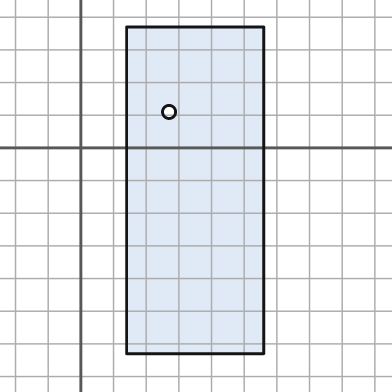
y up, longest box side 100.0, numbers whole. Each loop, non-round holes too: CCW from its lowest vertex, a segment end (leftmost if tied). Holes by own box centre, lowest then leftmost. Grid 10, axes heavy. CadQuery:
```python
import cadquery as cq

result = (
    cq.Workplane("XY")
    .moveTo(14.0, -63.0)
    .lineTo(56.0, -63.0)
    .lineTo(56.0, 37.0)
    .lineTo(14.0, 37.0)
    .close()
    .moveTo(27.0, 11.0)
    .circle(2.0)
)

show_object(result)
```